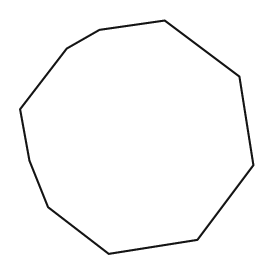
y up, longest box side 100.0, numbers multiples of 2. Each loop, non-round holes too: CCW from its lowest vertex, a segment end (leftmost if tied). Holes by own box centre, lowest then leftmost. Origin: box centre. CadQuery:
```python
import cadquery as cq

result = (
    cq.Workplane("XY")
    .moveTo(-12.0, -50.0)
    .lineTo(26.0, -44.0)
    .lineTo(50.0, -12.0)
    .lineTo(44.0, 26.0)
    .lineTo(12.0, 50.0)
    .lineTo(-16.0, 46.0)
    .lineTo(-30.0, 38.0)
    .lineTo(-50.0, 12.0)
    .lineTo(-46.0, -10.0)
    .lineTo(-38.0, -30.0)
    .close()
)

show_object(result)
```